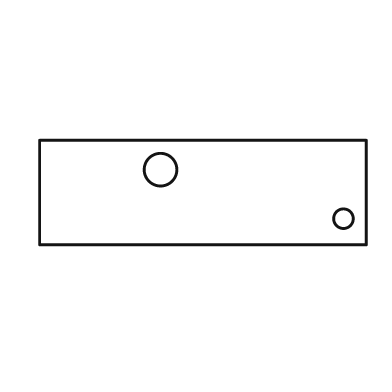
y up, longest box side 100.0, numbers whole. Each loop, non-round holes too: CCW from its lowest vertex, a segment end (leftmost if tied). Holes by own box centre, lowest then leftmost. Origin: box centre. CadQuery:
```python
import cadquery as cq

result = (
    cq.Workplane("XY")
    .moveTo(-50.0, -16.0)
    .lineTo(50.0, -16.0)
    .lineTo(50.0, 16.0)
    .lineTo(-50.0, 16.0)
    .close()
    .moveTo(43.0, -8.0)
    .circle(3.0)
    .moveTo(-13.0, 7.0)
    .circle(5.0)
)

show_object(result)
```